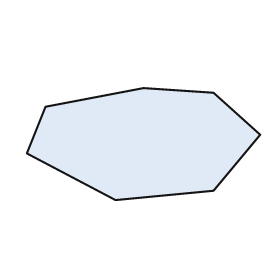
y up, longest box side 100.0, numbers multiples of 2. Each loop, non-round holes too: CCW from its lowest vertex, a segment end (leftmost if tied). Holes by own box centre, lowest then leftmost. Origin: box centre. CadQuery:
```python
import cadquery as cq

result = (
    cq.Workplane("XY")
    .moveTo(-12.0, -24.0)
    .lineTo(30.0, -20.0)
    .lineTo(50.0, 4.0)
    .lineTo(30.0, 22.0)
    .lineTo(0.0, 24.0)
    .lineTo(-42.0, 16.0)
    .lineTo(-50.0, -4.0)
    .close()
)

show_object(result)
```